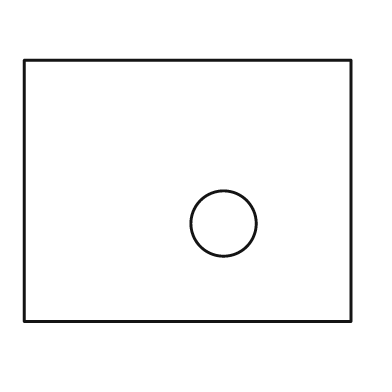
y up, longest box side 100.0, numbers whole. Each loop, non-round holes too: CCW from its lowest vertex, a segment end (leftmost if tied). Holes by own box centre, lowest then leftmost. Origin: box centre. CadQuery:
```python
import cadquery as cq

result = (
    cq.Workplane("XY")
    .moveTo(-50.0, -40.0)
    .lineTo(50.0, -40.0)
    .lineTo(50.0, 40.0)
    .lineTo(-50.0, 40.0)
    .close()
    .moveTo(11.0, -10.0)
    .circle(10.0)
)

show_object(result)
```